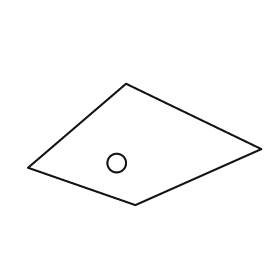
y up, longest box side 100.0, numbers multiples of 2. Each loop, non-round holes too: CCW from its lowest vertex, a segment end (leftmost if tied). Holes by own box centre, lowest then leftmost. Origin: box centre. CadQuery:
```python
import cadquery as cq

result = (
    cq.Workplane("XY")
    .moveTo(-4.0, -26.0)
    .lineTo(50.0, -2.0)
    .lineTo(-8.0, 26.0)
    .lineTo(-50.0, -10.0)
    .close()
    .moveTo(-12.0, -8.0)
    .circle(4.0)
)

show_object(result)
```